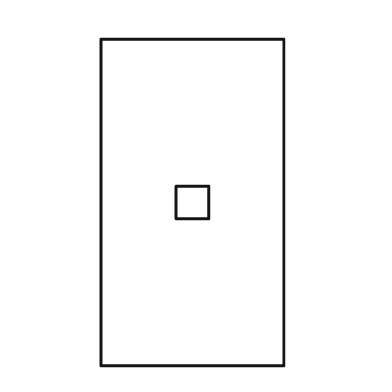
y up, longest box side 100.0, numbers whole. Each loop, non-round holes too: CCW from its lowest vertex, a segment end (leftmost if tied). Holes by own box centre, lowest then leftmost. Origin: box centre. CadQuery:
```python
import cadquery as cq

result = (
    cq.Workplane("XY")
    .moveTo(-28.0, -50.0)
    .lineTo(28.0, -50.0)
    .lineTo(28.0, 50.0)
    .lineTo(-28.0, 50.0)
    .close()
    .moveTo(-5.0, -5.0)
    .lineTo(5.0, -5.0)
    .lineTo(5.0, 5.0)
    .lineTo(-5.0, 5.0)
    .close()
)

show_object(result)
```